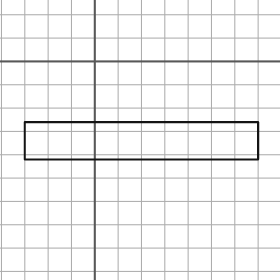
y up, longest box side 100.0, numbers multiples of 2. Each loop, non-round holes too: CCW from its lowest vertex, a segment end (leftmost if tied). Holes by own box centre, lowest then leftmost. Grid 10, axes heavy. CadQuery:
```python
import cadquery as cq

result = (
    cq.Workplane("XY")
    .moveTo(-30.0, -42.0)
    .lineTo(70.0, -42.0)
    .lineTo(70.0, -26.0)
    .lineTo(-30.0, -26.0)
    .close()
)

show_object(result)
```